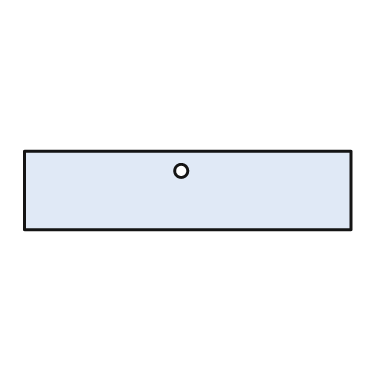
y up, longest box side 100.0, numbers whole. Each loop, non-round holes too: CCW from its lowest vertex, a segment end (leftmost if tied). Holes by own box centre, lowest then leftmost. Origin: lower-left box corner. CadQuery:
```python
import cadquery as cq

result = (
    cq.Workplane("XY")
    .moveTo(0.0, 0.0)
    .lineTo(100.0, 0.0)
    .lineTo(100.0, 24.0)
    .lineTo(0.0, 24.0)
    .close()
    .moveTo(48.0, 18.0)
    .circle(2.0)
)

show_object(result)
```